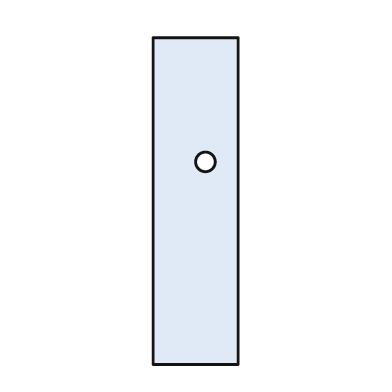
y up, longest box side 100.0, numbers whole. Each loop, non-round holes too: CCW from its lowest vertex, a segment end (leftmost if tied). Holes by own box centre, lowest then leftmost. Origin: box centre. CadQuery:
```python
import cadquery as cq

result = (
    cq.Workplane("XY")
    .moveTo(-13.0, -50.0)
    .lineTo(13.0, -50.0)
    .lineTo(13.0, 50.0)
    .lineTo(-13.0, 50.0)
    .close()
    .moveTo(3.0, 12.0)
    .circle(3.0)
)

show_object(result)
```